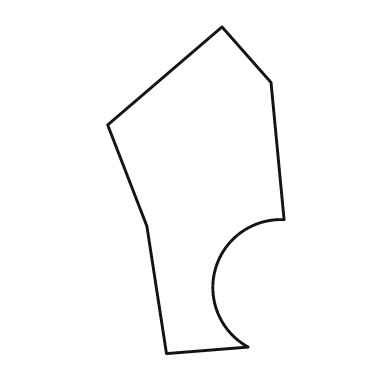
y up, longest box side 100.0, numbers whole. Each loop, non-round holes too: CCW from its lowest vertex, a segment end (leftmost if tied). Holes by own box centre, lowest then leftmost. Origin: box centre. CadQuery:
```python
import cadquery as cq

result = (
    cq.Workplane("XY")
    .moveTo(-9.0, -50.0)
    .lineTo(16.0, -48.0)
    .threePointArc((6.0, -24.0), (27.0, -9.0))
    .lineTo(23.0, 33.0)
    .lineTo(8.0, 50.0)
    .lineTo(-27.0, 20.0)
    .lineTo(-15.0, -11.0)
    .close()
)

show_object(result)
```